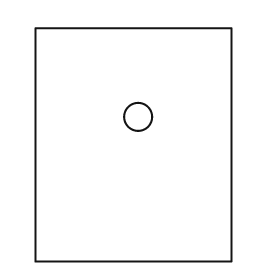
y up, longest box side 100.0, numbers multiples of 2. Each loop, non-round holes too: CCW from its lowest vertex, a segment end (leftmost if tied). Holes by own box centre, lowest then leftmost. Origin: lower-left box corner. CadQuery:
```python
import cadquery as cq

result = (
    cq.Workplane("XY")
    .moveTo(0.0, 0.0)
    .lineTo(84.0, 0.0)
    .lineTo(84.0, 100.0)
    .lineTo(0.0, 100.0)
    .close()
    .moveTo(44.0, 62.0)
    .circle(6.0)
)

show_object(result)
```